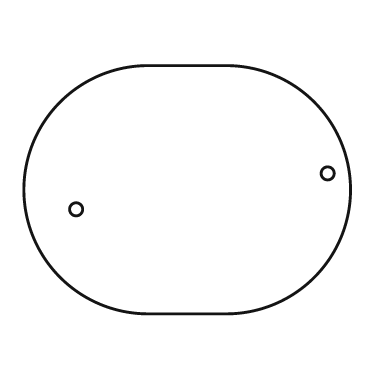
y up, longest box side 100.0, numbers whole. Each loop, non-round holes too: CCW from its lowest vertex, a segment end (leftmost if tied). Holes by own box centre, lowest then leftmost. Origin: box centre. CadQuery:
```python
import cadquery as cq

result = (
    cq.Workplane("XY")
    .moveTo(-12.0, -38.0)
    .lineTo(12.0, -38.0)
    .threePointArc((50.0, 0.0), (12.0, 38.0))
    .lineTo(-12.0, 38.0)
    .threePointArc((-50.0, 0.0), (-12.0, -38.0))
    .close()
    .moveTo(-34.0, -6.0)
    .circle(2.0)
    .moveTo(43.0, 5.0)
    .circle(2.0)
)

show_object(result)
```